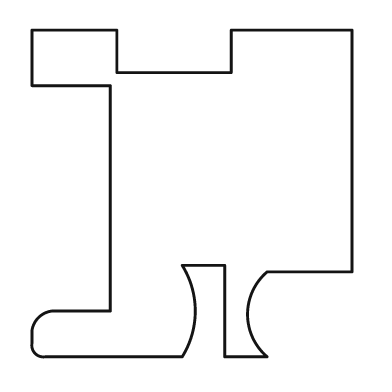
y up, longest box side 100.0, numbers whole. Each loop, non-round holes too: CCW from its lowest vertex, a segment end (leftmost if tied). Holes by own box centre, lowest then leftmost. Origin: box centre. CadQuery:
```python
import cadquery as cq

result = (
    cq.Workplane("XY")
    .moveTo(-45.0, -50.0)
    .lineTo(-3.0, -50.0)
    .threePointArc((1.0, -36.0), (-3.0, -22.0))
    .lineTo(10.0, -22.0)
    .lineTo(10.0, -50.0)
    .lineTo(23.0, -50.0)
    .threePointArc((17.0, -37.0), (23.0, -24.0))
    .lineTo(49.0, -24.0)
    .lineTo(49.0, 50.0)
    .lineTo(12.0, 50.0)
    .lineTo(12.0, 37.0)
    .lineTo(-23.0, 37.0)
    .lineTo(-23.0, 50.0)
    .lineTo(-49.0, 50.0)
    .lineTo(-49.0, 33.0)
    .lineTo(-25.0, 33.0)
    .lineTo(-25.0, -36.0)
    .lineTo(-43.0, -36.0)
    .threePointArc((-47.0, -38.0), (-49.0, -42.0))
    .lineTo(-49.0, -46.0)
    .threePointArc((-48.0, -49.0), (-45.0, -50.0))
    .close()
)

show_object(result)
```